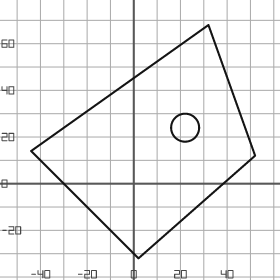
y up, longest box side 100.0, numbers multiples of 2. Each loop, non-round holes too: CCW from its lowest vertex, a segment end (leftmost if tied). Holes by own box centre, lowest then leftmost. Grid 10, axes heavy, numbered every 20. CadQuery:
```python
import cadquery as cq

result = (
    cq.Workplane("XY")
    .moveTo(2.0, -32.0)
    .lineTo(52.0, 12.0)
    .lineTo(32.0, 68.0)
    .lineTo(-44.0, 14.0)
    .close()
    .moveTo(22.0, 24.0)
    .circle(6.0)
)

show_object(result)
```